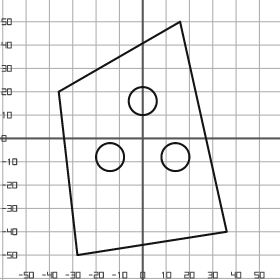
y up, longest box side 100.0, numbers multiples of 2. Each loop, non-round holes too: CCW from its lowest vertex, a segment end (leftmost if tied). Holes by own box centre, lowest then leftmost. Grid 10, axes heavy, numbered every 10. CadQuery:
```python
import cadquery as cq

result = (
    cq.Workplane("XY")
    .moveTo(-28.0, -50.0)
    .lineTo(36.0, -40.0)
    .lineTo(16.0, 50.0)
    .lineTo(-36.0, 20.0)
    .close()
    .moveTo(-14.0, -8.0)
    .circle(6.0)
    .moveTo(14.0, -8.0)
    .circle(6.0)
    .moveTo(0.0, 16.0)
    .circle(6.0)
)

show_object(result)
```